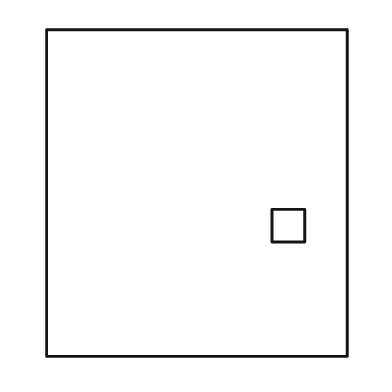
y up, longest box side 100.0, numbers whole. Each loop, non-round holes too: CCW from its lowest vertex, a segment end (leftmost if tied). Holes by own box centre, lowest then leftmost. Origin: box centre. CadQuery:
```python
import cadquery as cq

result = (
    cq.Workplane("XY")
    .moveTo(-46.0, -50.0)
    .lineTo(46.0, -50.0)
    .lineTo(46.0, 50.0)
    .lineTo(-46.0, 50.0)
    .close()
    .moveTo(23.0, -15.0)
    .lineTo(33.0, -15.0)
    .lineTo(33.0, -5.0)
    .lineTo(23.0, -5.0)
    .close()
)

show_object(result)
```